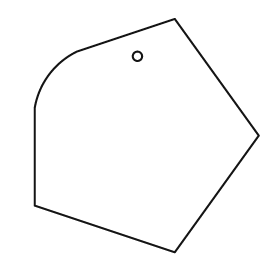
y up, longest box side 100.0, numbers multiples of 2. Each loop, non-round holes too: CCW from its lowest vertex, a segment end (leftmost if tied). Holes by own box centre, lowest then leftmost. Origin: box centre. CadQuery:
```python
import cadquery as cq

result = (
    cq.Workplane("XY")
    .moveTo(12.0, -50.0)
    .lineTo(48.0, 0.0)
    .lineTo(12.0, 50.0)
    .lineTo(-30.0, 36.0)
    .threePointArc((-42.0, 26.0), (-48.0, 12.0))
    .lineTo(-48.0, -30.0)
    .close()
    .moveTo(-4.0, 34.0)
    .circle(2.0)
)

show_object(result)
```